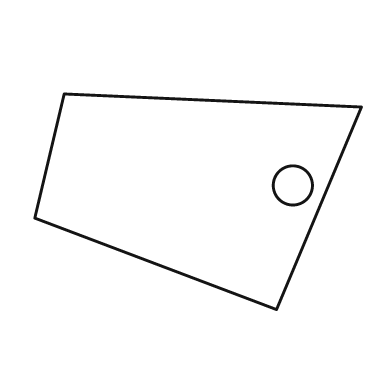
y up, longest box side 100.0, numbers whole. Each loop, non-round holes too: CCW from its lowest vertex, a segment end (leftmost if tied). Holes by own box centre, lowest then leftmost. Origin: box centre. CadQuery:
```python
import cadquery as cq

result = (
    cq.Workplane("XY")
    .moveTo(24.0, -33.0)
    .lineTo(50.0, 29.0)
    .lineTo(-41.0, 33.0)
    .lineTo(-50.0, -5.0)
    .close()
    .moveTo(29.0, 5.0)
    .circle(6.0)
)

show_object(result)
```